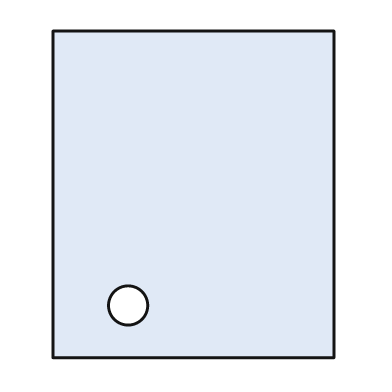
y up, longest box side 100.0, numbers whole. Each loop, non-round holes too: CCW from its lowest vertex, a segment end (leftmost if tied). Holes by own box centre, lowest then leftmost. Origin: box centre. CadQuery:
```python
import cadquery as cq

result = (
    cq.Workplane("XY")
    .moveTo(-43.0, -50.0)
    .lineTo(43.0, -50.0)
    .lineTo(43.0, 50.0)
    .lineTo(-43.0, 50.0)
    .close()
    .moveTo(-20.0, -34.0)
    .circle(6.0)
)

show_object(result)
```